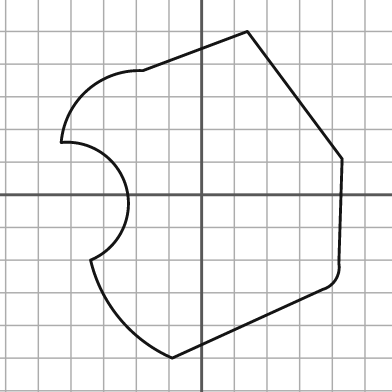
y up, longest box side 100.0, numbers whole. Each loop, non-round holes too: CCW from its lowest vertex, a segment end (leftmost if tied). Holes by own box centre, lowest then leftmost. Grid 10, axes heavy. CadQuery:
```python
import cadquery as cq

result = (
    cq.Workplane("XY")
    .moveTo(-9.0, -50.0)
    .lineTo(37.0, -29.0)
    .threePointArc((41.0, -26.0), (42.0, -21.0))
    .lineTo(43.0, 11.0)
    .lineTo(14.0, 50.0)
    .lineTo(-18.0, 38.0)
    .threePointArc((-35.0, 32.0), (-43.0, 16.0))
    .threePointArc((-23.0, 2.0), (-34.0, -20.0))
    .threePointArc((-25.0, -38.0), (-9.0, -50.0))
    .close()
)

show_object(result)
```